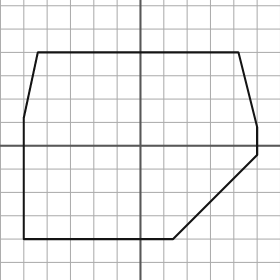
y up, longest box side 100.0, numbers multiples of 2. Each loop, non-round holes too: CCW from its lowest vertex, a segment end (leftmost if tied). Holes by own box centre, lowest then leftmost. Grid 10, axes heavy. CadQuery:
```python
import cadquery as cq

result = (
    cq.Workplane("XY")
    .moveTo(-50.0, -40.0)
    .lineTo(14.0, -40.0)
    .lineTo(50.0, -4.0)
    .lineTo(50.0, 8.0)
    .lineTo(42.0, 40.0)
    .lineTo(-44.0, 40.0)
    .lineTo(-50.0, 12.0)
    .close()
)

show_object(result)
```